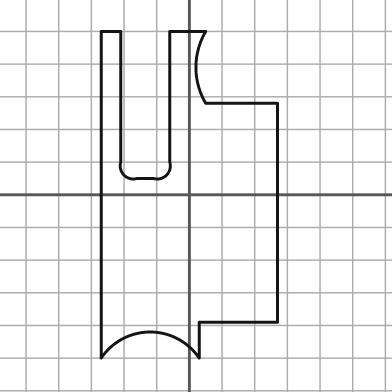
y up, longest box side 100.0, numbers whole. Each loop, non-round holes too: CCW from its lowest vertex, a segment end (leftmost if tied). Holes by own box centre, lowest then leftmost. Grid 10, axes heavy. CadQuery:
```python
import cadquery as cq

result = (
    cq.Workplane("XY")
    .moveTo(-27.0, -50.0)
    .threePointArc((-12.0, -42.0), (3.0, -50.0))
    .lineTo(3.0, -39.0)
    .lineTo(27.0, -39.0)
    .lineTo(27.0, 28.0)
    .lineTo(5.0, 28.0)
    .threePointArc((2.0, 39.0), (5.0, 50.0))
    .lineTo(-6.0, 50.0)
    .lineTo(-6.0, 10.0)
    .threePointArc((-7.0, 6.0), (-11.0, 5.0))
    .lineTo(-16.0, 5.0)
    .threePointArc((-20.0, 6.0), (-21.0, 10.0))
    .lineTo(-21.0, 50.0)
    .lineTo(-27.0, 50.0)
    .close()
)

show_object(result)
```